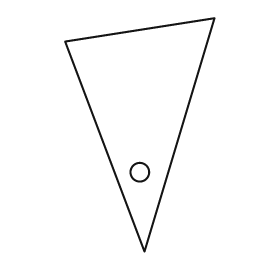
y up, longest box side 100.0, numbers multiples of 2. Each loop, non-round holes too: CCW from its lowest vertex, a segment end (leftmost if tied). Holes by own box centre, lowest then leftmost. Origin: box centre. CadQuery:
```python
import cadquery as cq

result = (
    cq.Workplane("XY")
    .moveTo(2.0, -50.0)
    .lineTo(32.0, 50.0)
    .lineTo(-32.0, 40.0)
    .close()
    .moveTo(0.0, -16.0)
    .circle(4.0)
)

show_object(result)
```